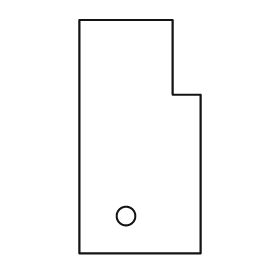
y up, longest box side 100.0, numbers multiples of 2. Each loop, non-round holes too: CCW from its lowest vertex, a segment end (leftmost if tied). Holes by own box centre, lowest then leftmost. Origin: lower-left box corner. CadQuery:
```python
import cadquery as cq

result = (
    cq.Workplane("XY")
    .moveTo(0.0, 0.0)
    .lineTo(52.0, 0.0)
    .lineTo(52.0, 68.0)
    .lineTo(40.0, 68.0)
    .lineTo(40.0, 100.0)
    .lineTo(0.0, 100.0)
    .close()
    .moveTo(20.0, 16.0)
    .circle(4.0)
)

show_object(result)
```